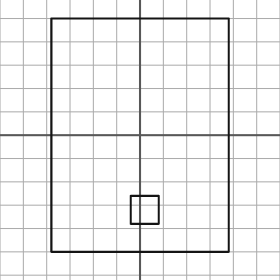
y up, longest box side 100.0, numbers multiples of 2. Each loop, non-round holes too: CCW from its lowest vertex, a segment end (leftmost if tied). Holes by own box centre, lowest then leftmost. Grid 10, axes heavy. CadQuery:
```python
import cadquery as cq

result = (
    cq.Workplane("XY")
    .moveTo(-38.0, -50.0)
    .lineTo(38.0, -50.0)
    .lineTo(38.0, 50.0)
    .lineTo(-38.0, 50.0)
    .close()
    .moveTo(-4.0, -38.0)
    .lineTo(8.0, -38.0)
    .lineTo(8.0, -26.0)
    .lineTo(-4.0, -26.0)
    .close()
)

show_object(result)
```